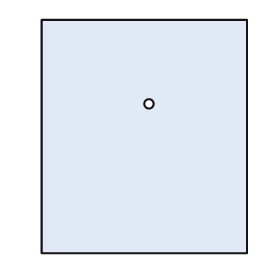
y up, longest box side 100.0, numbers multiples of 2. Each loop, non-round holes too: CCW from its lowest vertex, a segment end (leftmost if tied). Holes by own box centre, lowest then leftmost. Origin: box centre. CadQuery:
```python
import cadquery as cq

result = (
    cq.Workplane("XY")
    .moveTo(-44.0, -50.0)
    .lineTo(44.0, -50.0)
    .lineTo(44.0, 50.0)
    .lineTo(-44.0, 50.0)
    .close()
    .moveTo(2.0, 14.0)
    .circle(2.0)
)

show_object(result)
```